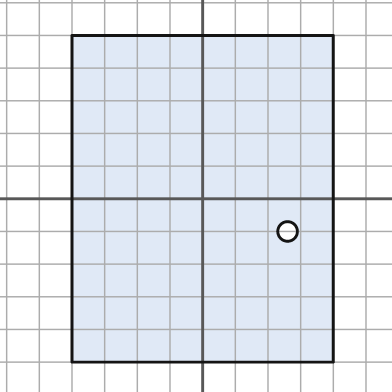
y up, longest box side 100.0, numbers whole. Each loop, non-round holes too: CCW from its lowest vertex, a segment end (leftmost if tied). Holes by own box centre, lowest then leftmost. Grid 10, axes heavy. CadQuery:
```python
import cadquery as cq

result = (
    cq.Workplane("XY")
    .moveTo(-40.0, -50.0)
    .lineTo(40.0, -50.0)
    .lineTo(40.0, 50.0)
    .lineTo(-40.0, 50.0)
    .close()
    .moveTo(26.0, -10.0)
    .circle(3.0)
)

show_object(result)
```